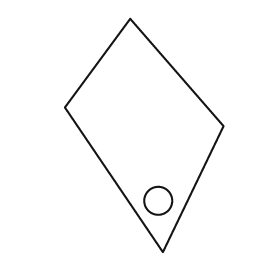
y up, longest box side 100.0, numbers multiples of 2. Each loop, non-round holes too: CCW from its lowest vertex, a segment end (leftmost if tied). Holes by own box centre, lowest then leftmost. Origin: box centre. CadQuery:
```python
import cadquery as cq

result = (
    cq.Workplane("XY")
    .moveTo(8.0, -50.0)
    .lineTo(34.0, 4.0)
    .lineTo(-6.0, 50.0)
    .lineTo(-34.0, 12.0)
    .close()
    .moveTo(6.0, -28.0)
    .circle(6.0)
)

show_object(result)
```